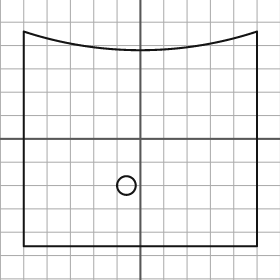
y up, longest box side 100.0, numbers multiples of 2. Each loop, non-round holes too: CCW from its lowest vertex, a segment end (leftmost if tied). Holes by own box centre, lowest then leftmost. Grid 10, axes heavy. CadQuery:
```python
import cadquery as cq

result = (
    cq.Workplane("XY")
    .moveTo(-50.0, -46.0)
    .lineTo(50.0, -46.0)
    .lineTo(50.0, 46.0)
    .threePointArc((0.0, 38.0), (-50.0, 46.0))
    .close()
    .moveTo(-6.0, -20.0)
    .circle(4.0)
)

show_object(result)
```